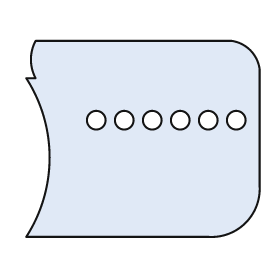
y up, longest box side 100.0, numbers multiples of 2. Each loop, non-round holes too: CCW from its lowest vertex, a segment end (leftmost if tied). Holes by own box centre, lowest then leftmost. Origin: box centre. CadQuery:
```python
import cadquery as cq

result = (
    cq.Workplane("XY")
    .moveTo(-50.0, -42.0)
    .lineTo(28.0, -42.0)
    .threePointArc((44.0, -36.0), (50.0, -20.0))
    .lineTo(50.0, 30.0)
    .threePointArc((46.0, 38.0), (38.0, 42.0))
    .lineTo(-46.0, 42.0)
    .threePointArc((-48.0, 34.0), (-46.0, 26.0))
    .lineTo(-50.0, 26.0)
    .threePointArc((-40.0, -8.0), (-50.0, -42.0))
    .close()
    .moveTo(-20.0, 8.0)
    .circle(4.0)
    .moveTo(-8.0, 8.0)
    .circle(4.0)
    .moveTo(4.0, 8.0)
    .circle(4.0)
    .moveTo(16.0, 8.0)
    .circle(4.0)
    .moveTo(28.0, 8.0)
    .circle(4.0)
    .moveTo(40.0, 8.0)
    .circle(4.0)
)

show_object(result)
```